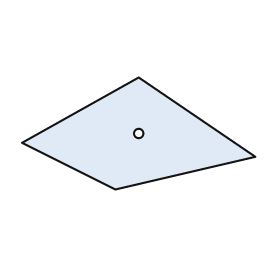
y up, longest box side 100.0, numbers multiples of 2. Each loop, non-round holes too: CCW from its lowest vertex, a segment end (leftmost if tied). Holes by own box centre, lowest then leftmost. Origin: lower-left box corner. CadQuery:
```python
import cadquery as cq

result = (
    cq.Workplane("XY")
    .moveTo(40.0, 0.0)
    .lineTo(100.0, 14.0)
    .lineTo(50.0, 48.0)
    .lineTo(0.0, 20.0)
    .close()
    .moveTo(50.0, 24.0)
    .circle(2.0)
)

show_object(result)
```